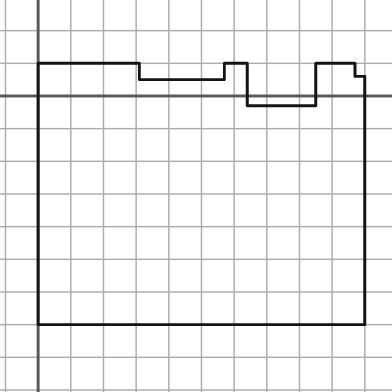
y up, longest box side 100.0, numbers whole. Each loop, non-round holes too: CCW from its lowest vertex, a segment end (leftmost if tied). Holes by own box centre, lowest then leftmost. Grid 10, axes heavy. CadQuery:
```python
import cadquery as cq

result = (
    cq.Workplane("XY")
    .moveTo(0.0, -70.0)
    .lineTo(100.0, -70.0)
    .lineTo(100.0, 6.0)
    .lineTo(97.0, 6.0)
    .lineTo(97.0, 10.0)
    .lineTo(85.0, 10.0)
    .lineTo(85.0, -3.0)
    .lineTo(64.0, -3.0)
    .lineTo(64.0, 10.0)
    .lineTo(57.0, 10.0)
    .lineTo(57.0, 5.0)
    .lineTo(31.0, 5.0)
    .lineTo(31.0, 10.0)
    .lineTo(0.0, 10.0)
    .close()
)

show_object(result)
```